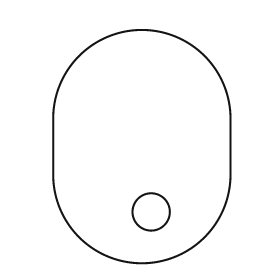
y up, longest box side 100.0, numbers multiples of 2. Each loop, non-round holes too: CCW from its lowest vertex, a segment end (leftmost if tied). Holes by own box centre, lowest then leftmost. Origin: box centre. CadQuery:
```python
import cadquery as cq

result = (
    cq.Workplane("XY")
    .moveTo(-38.0, -12.0)
    .threePointArc((0.0, -50.0), (38.0, -12.0))
    .lineTo(38.0, 12.0)
    .threePointArc((0.0, 50.0), (-38.0, 12.0))
    .close()
    .moveTo(4.0, -28.0)
    .circle(8.0)
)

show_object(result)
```